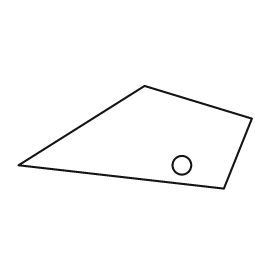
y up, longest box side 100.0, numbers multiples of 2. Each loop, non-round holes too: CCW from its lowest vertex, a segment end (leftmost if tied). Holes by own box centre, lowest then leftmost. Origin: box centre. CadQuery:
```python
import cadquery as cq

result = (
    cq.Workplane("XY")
    .moveTo(38.0, -22.0)
    .lineTo(50.0, 8.0)
    .lineTo(4.0, 22.0)
    .lineTo(-50.0, -12.0)
    .close()
    .moveTo(20.0, -12.0)
    .circle(4.0)
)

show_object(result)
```